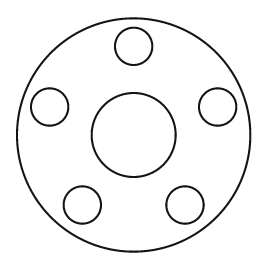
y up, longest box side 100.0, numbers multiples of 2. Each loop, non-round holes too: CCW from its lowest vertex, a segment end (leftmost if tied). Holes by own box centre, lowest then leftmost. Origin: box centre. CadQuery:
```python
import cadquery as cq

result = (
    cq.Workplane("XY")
    .moveTo(0.0, 0.0)
    .circle(50.0)
    .moveTo(-22.0, -30.0)
    .circle(8.0)
    .moveTo(22.0, -30.0)
    .circle(8.0)
    .moveTo(0.0, 0.0)
    .circle(18.0)
    .moveTo(-36.0, 12.0)
    .circle(8.0)
    .moveTo(36.0, 12.0)
    .circle(8.0)
    .moveTo(0.0, 38.0)
    .circle(8.0)
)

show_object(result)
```